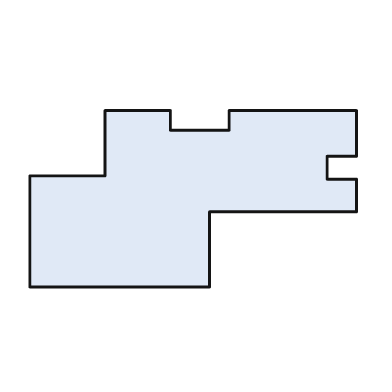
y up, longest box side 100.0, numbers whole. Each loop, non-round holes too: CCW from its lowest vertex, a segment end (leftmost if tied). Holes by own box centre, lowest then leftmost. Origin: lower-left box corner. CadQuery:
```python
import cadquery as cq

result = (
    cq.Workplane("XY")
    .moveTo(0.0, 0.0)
    .lineTo(55.0, 0.0)
    .lineTo(55.0, 23.0)
    .lineTo(100.0, 23.0)
    .lineTo(100.0, 33.0)
    .lineTo(91.0, 33.0)
    .lineTo(91.0, 40.0)
    .lineTo(100.0, 40.0)
    .lineTo(100.0, 54.0)
    .lineTo(61.0, 54.0)
    .lineTo(61.0, 48.0)
    .lineTo(43.0, 48.0)
    .lineTo(43.0, 54.0)
    .lineTo(23.0, 54.0)
    .lineTo(23.0, 34.0)
    .lineTo(0.0, 34.0)
    .close()
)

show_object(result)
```